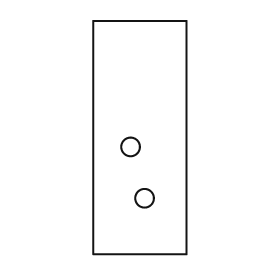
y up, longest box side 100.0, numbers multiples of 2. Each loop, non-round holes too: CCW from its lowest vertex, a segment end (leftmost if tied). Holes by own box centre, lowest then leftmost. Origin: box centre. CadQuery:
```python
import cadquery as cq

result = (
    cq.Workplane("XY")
    .moveTo(-20.0, -50.0)
    .lineTo(20.0, -50.0)
    .lineTo(20.0, 50.0)
    .lineTo(-20.0, 50.0)
    .close()
    .moveTo(2.0, -26.0)
    .circle(4.0)
    .moveTo(-4.0, -4.0)
    .circle(4.0)
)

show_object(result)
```